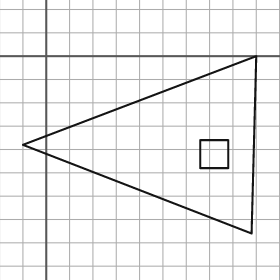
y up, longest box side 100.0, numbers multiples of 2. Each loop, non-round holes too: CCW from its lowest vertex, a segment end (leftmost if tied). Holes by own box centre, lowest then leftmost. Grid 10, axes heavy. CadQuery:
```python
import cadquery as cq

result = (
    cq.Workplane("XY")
    .moveTo(88.0, -76.0)
    .lineTo(90.0, 0.0)
    .lineTo(-10.0, -38.0)
    .close()
    .moveTo(66.0, -48.0)
    .lineTo(78.0, -48.0)
    .lineTo(78.0, -36.0)
    .lineTo(66.0, -36.0)
    .close()
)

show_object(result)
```